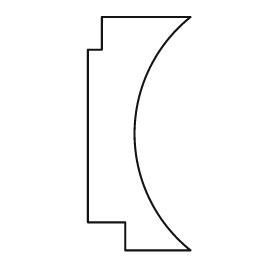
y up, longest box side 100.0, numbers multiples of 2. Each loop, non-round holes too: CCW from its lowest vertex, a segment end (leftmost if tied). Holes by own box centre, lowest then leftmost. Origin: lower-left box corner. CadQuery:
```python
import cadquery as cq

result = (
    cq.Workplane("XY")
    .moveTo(16.0, 0.0)
    .lineTo(44.0, 0.0)
    .threePointArc((20.0, 50.0), (44.0, 100.0))
    .lineTo(6.0, 100.0)
    .lineTo(6.0, 86.0)
    .lineTo(0.0, 86.0)
    .lineTo(0.0, 12.0)
    .lineTo(16.0, 12.0)
    .close()
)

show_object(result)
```